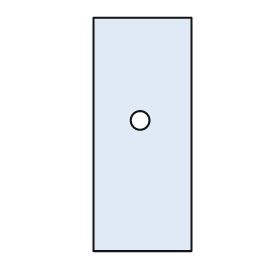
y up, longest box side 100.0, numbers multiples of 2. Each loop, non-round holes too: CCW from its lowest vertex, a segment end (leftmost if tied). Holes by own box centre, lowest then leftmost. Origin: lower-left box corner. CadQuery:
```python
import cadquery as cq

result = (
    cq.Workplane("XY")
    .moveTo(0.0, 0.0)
    .lineTo(42.0, 0.0)
    .lineTo(42.0, 100.0)
    .lineTo(0.0, 100.0)
    .close()
    .moveTo(20.0, 56.0)
    .circle(4.0)
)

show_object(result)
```